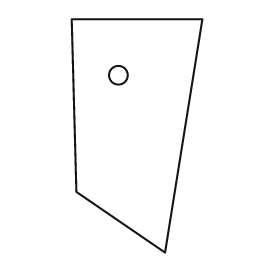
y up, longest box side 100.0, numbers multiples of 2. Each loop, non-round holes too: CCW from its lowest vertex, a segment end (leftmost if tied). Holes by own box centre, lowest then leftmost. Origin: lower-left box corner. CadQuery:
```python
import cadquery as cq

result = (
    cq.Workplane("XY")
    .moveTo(40.0, 0.0)
    .lineTo(56.0, 100.0)
    .lineTo(0.0, 100.0)
    .lineTo(2.0, 26.0)
    .close()
    .moveTo(20.0, 76.0)
    .circle(4.0)
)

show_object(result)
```